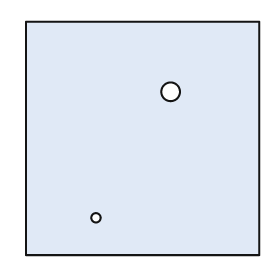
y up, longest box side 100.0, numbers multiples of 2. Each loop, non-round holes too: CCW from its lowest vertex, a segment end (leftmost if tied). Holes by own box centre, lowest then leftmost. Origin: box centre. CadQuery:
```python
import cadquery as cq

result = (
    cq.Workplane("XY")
    .moveTo(-50.0, -50.0)
    .lineTo(50.0, -50.0)
    .lineTo(50.0, 50.0)
    .lineTo(-50.0, 50.0)
    .close()
    .moveTo(-20.0, -34.0)
    .circle(2.0)
    .moveTo(12.0, 20.0)
    .circle(4.0)
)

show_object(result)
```